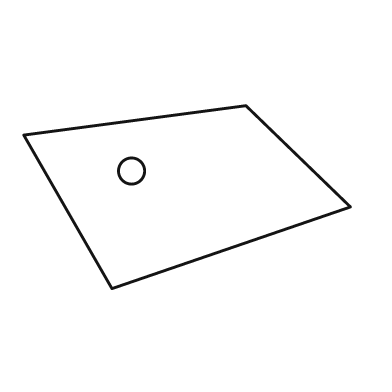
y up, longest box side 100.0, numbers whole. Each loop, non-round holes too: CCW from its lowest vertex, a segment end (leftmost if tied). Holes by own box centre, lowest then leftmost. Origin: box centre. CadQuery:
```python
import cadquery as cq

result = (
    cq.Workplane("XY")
    .moveTo(-23.0, -28.0)
    .lineTo(50.0, -3.0)
    .lineTo(18.0, 28.0)
    .lineTo(-50.0, 19.0)
    .close()
    .moveTo(-17.0, 8.0)
    .circle(4.0)
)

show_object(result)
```